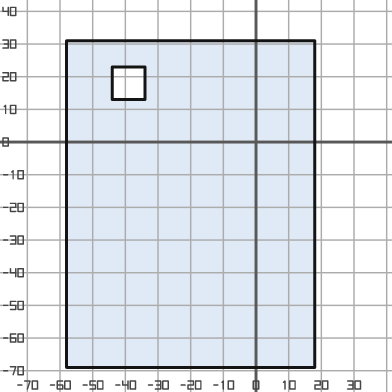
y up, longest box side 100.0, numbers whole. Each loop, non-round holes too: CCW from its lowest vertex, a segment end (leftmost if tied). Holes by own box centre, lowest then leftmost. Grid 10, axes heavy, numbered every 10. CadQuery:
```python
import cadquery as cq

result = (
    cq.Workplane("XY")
    .moveTo(-58.0, -69.0)
    .lineTo(18.0, -69.0)
    .lineTo(18.0, 31.0)
    .lineTo(-58.0, 31.0)
    .close()
    .moveTo(-44.0, 13.0)
    .lineTo(-34.0, 13.0)
    .lineTo(-34.0, 23.0)
    .lineTo(-44.0, 23.0)
    .close()
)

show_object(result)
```